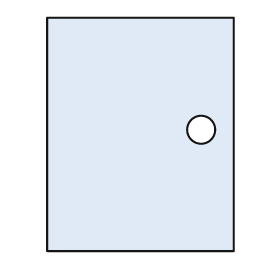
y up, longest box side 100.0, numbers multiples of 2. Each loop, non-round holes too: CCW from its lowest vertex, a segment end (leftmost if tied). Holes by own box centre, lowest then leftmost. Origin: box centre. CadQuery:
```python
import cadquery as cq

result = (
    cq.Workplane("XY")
    .moveTo(-40.0, -50.0)
    .lineTo(40.0, -50.0)
    .lineTo(40.0, 50.0)
    .lineTo(-40.0, 50.0)
    .close()
    .moveTo(26.0, 2.0)
    .circle(6.0)
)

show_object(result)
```